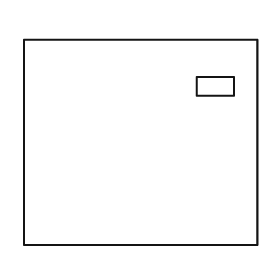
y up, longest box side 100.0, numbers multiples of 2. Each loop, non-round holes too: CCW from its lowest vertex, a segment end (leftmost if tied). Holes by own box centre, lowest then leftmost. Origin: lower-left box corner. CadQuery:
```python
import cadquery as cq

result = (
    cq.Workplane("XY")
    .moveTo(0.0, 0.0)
    .lineTo(100.0, 0.0)
    .lineTo(100.0, 88.0)
    .lineTo(0.0, 88.0)
    .close()
    .moveTo(74.0, 64.0)
    .lineTo(90.0, 64.0)
    .lineTo(90.0, 72.0)
    .lineTo(74.0, 72.0)
    .close()
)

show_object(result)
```